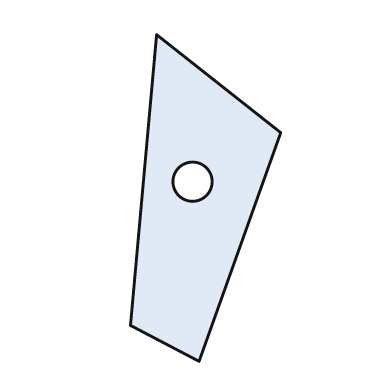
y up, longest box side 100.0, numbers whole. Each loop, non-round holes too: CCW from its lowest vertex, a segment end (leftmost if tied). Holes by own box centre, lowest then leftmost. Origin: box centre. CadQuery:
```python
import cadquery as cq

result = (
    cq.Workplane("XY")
    .moveTo(-2.0, -50.0)
    .lineTo(23.0, 20.0)
    .lineTo(-15.0, 50.0)
    .lineTo(-23.0, -39.0)
    .close()
    .moveTo(-4.0, 5.0)
    .circle(6.0)
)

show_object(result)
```